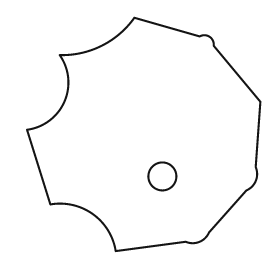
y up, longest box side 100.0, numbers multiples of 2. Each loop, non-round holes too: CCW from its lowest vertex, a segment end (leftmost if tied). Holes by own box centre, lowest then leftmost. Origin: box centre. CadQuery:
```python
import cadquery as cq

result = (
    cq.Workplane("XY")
    .moveTo(-12.0, -50.0)
    .lineTo(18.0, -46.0)
    .threePointArc((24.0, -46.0), (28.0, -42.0))
    .lineTo(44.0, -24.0)
    .threePointArc((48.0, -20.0), (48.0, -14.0))
    .lineTo(50.0, 14.0)
    .lineTo(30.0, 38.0)
    .threePointArc((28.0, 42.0), (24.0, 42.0))
    .lineTo(-4.0, 50.0)
    .threePointArc((-18.0, 38.0), (-36.0, 34.0))
    .threePointArc((-34.0, 14.0), (-50.0, 2.0))
    .lineTo(-40.0, -30.0)
    .threePointArc((-22.0, -34.0), (-12.0, -50.0))
    .close()
    .moveTo(8.0, -18.0)
    .circle(6.0)
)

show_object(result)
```